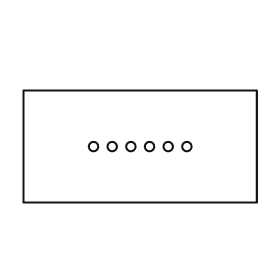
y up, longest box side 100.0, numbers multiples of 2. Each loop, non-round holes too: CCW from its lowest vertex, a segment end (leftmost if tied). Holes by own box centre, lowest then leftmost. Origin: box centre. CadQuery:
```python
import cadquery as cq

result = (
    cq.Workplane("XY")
    .moveTo(-50.0, -24.0)
    .lineTo(50.0, -24.0)
    .lineTo(50.0, 24.0)
    .lineTo(-50.0, 24.0)
    .close()
    .moveTo(-20.0, 0.0)
    .circle(2.0)
    .moveTo(-12.0, 0.0)
    .circle(2.0)
    .moveTo(-4.0, 0.0)
    .circle(2.0)
    .moveTo(4.0, 0.0)
    .circle(2.0)
    .moveTo(12.0, 0.0)
    .circle(2.0)
    .moveTo(20.0, 0.0)
    .circle(2.0)
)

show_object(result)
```